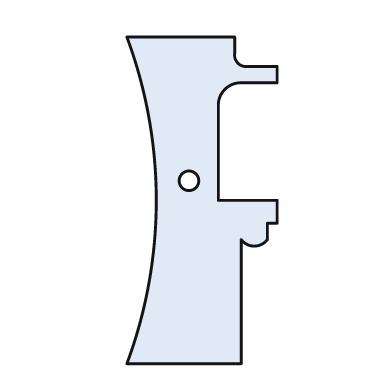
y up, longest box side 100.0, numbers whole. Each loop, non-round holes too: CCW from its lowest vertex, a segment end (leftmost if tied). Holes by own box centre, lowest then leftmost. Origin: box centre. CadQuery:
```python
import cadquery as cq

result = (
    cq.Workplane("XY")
    .moveTo(-23.0, -50.0)
    .lineTo(12.0, -50.0)
    .lineTo(12.0, -12.0)
    .threePointArc((16.0, -14.0), (20.0, -12.0))
    .lineTo(20.0, -7.0)
    .lineTo(23.0, -7.0)
    .lineTo(23.0, 0.0)
    .lineTo(5.0, 0.0)
    .lineTo(5.0, 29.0)
    .threePointArc((7.0, 34.0), (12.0, 36.0))
    .lineTo(23.0, 36.0)
    .lineTo(23.0, 41.0)
    .lineTo(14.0, 41.0)
    .threePointArc((11.0, 42.0), (10.0, 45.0))
    .lineTo(10.0, 50.0)
    .lineTo(-23.0, 50.0)
    .threePointArc((-14.0, 0.0), (-23.0, -50.0))
    .close()
    .moveTo(-4.0, 6.0)
    .circle(3.0)
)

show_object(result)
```